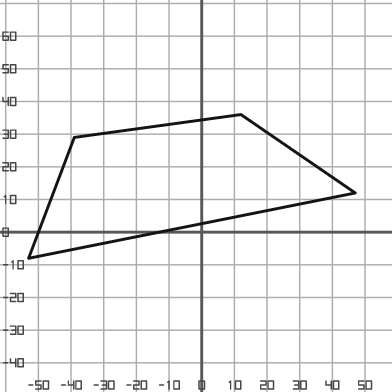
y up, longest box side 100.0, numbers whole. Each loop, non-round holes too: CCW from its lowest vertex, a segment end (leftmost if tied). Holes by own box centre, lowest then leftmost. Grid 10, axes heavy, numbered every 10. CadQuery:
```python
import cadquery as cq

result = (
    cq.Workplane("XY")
    .moveTo(-53.0, -8.0)
    .lineTo(47.0, 12.0)
    .lineTo(12.0, 36.0)
    .lineTo(-39.0, 29.0)
    .close()
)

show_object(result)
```